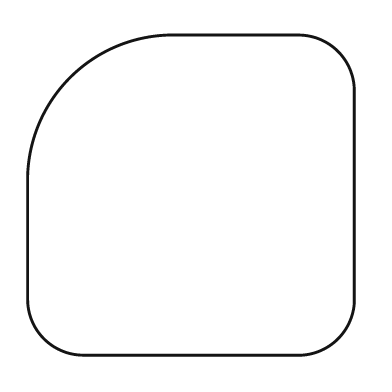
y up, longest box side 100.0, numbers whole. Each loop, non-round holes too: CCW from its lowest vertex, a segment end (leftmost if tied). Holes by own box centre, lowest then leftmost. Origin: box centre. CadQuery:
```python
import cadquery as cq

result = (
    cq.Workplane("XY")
    .moveTo(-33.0, -49.0)
    .lineTo(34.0, -49.0)
    .threePointArc((45.0, -44.0), (50.0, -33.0))
    .lineTo(50.0, 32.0)
    .threePointArc((45.0, 44.0), (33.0, 49.0))
    .lineTo(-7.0, 49.0)
    .threePointArc((-37.0, 36.0), (-50.0, 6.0))
    .lineTo(-50.0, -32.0)
    .threePointArc((-45.0, -44.0), (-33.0, -49.0))
    .close()
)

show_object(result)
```